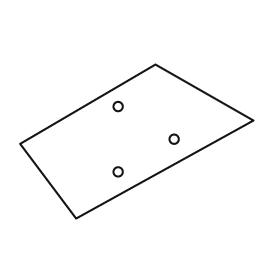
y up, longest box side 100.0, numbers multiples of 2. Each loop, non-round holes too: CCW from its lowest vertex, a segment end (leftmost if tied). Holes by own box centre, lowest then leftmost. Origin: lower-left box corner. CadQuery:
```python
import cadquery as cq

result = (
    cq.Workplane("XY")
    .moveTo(24.0, 0.0)
    .lineTo(100.0, 42.0)
    .lineTo(58.0, 66.0)
    .lineTo(0.0, 32.0)
    .close()
    .moveTo(42.0, 20.0)
    .circle(2.0)
    .moveTo(66.0, 34.0)
    .circle(2.0)
    .moveTo(42.0, 48.0)
    .circle(2.0)
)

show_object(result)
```